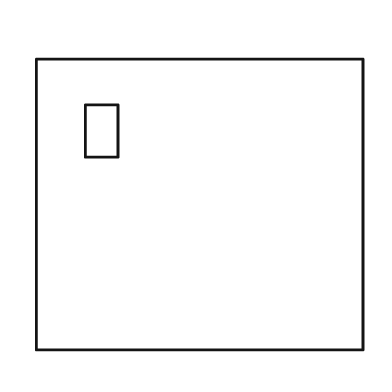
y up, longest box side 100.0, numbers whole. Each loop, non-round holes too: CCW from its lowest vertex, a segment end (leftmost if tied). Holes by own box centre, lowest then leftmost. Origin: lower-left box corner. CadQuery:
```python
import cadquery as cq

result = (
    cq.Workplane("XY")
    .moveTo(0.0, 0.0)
    .lineTo(100.0, 0.0)
    .lineTo(100.0, 89.0)
    .lineTo(0.0, 89.0)
    .close()
    .moveTo(15.0, 59.0)
    .lineTo(25.0, 59.0)
    .lineTo(25.0, 75.0)
    .lineTo(15.0, 75.0)
    .close()
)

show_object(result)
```